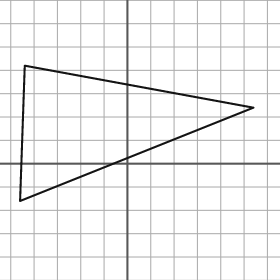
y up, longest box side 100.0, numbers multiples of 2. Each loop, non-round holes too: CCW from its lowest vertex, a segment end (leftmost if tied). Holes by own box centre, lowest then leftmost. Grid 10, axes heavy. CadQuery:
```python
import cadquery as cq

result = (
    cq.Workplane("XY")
    .moveTo(-46.0, -16.0)
    .lineTo(54.0, 24.0)
    .lineTo(-44.0, 42.0)
    .close()
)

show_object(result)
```